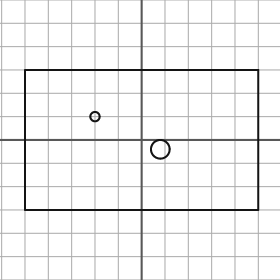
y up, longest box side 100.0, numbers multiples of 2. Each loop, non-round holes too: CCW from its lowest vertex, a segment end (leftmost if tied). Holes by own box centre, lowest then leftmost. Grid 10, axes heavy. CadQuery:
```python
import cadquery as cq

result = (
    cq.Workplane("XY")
    .moveTo(-50.0, -30.0)
    .lineTo(50.0, -30.0)
    .lineTo(50.0, 30.0)
    .lineTo(-50.0, 30.0)
    .close()
    .moveTo(8.0, -4.0)
    .circle(4.0)
    .moveTo(-20.0, 10.0)
    .circle(2.0)
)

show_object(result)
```